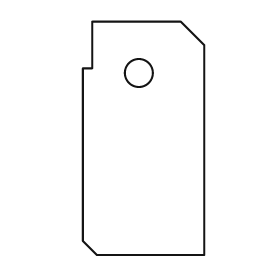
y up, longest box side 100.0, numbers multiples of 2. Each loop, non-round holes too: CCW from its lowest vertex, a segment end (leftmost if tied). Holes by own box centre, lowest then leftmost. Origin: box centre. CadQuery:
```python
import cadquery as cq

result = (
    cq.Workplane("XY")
    .moveTo(-20.0, -50.0)
    .lineTo(26.0, -50.0)
    .lineTo(26.0, 40.0)
    .lineTo(16.0, 50.0)
    .lineTo(-22.0, 50.0)
    .lineTo(-22.0, 30.0)
    .lineTo(-26.0, 30.0)
    .lineTo(-26.0, -44.0)
    .close()
    .moveTo(-2.0, 28.0)
    .circle(6.0)
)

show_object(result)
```